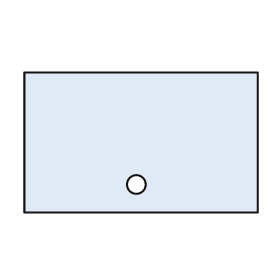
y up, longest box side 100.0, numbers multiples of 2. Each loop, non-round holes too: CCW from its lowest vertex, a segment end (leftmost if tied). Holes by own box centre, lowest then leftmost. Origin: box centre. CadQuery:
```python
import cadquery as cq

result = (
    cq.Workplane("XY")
    .moveTo(-50.0, -30.0)
    .lineTo(50.0, -30.0)
    .lineTo(50.0, 30.0)
    .lineTo(-50.0, 30.0)
    .close()
    .moveTo(-2.0, -18.0)
    .circle(4.0)
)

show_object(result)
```